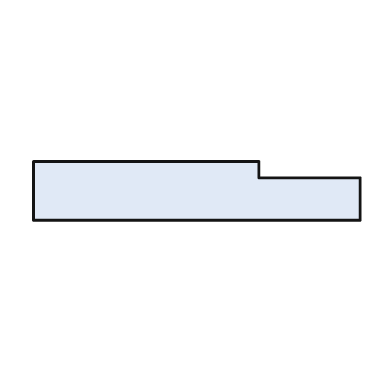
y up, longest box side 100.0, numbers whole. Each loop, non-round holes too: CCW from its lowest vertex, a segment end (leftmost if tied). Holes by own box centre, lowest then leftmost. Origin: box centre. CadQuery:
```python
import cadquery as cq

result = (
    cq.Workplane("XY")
    .moveTo(-50.0, -9.0)
    .lineTo(50.0, -9.0)
    .lineTo(50.0, 4.0)
    .lineTo(19.0, 4.0)
    .lineTo(19.0, 9.0)
    .lineTo(-50.0, 9.0)
    .close()
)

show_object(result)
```